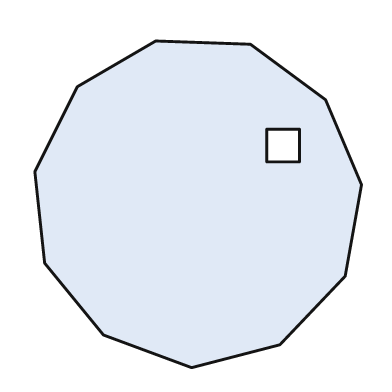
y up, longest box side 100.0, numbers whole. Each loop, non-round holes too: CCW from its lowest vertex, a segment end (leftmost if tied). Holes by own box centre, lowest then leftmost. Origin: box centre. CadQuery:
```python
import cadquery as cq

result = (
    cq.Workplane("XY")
    .moveTo(-2.0, -50.0)
    .lineTo(25.0, -43.0)
    .lineTo(45.0, -22.0)
    .lineTo(50.0, 6.0)
    .lineTo(39.0, 32.0)
    .lineTo(16.0, 49.0)
    .lineTo(-13.0, 50.0)
    .lineTo(-37.0, 36.0)
    .lineTo(-50.0, 10.0)
    .lineTo(-47.0, -18.0)
    .lineTo(-29.0, -40.0)
    .close()
    .moveTo(21.0, 13.0)
    .lineTo(31.0, 13.0)
    .lineTo(31.0, 23.0)
    .lineTo(21.0, 23.0)
    .close()
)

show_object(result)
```